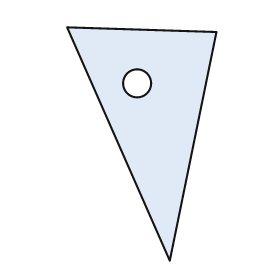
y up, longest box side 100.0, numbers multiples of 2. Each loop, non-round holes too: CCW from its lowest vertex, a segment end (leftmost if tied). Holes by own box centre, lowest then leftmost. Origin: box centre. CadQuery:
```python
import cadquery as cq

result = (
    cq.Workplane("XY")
    .moveTo(12.0, -50.0)
    .lineTo(32.0, 48.0)
    .lineTo(-32.0, 50.0)
    .close()
    .moveTo(-2.0, 26.0)
    .circle(6.0)
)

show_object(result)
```